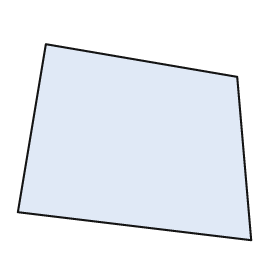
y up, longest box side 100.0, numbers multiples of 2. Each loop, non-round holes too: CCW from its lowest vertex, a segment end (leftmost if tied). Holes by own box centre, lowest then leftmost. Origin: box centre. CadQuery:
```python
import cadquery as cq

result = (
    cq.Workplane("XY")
    .moveTo(50.0, -42.0)
    .lineTo(44.0, 28.0)
    .lineTo(-38.0, 42.0)
    .lineTo(-50.0, -30.0)
    .close()
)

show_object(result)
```